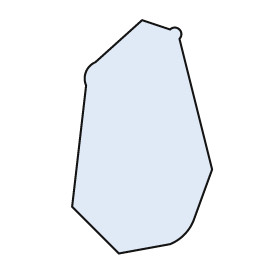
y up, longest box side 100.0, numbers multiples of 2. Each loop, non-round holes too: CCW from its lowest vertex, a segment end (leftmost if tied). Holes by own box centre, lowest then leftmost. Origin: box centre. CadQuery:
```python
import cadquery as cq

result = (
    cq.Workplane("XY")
    .moveTo(-10.0, -50.0)
    .lineTo(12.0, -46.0)
    .threePointArc((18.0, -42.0), (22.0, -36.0))
    .lineTo(30.0, -14.0)
    .lineTo(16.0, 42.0)
    .threePointArc((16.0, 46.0), (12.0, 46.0))
    .lineTo(0.0, 50.0)
    .lineTo(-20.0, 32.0)
    .threePointArc((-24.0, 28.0), (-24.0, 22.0))
    .lineTo(-30.0, -30.0)
    .close()
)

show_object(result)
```